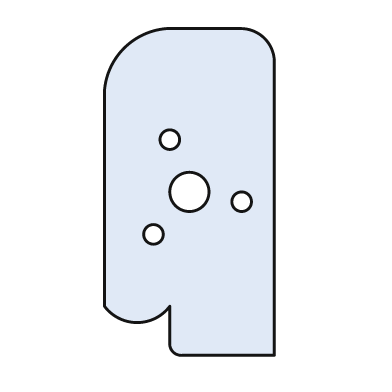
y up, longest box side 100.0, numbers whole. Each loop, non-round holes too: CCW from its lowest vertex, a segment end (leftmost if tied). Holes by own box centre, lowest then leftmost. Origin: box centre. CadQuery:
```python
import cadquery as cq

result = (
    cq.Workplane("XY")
    .moveTo(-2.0, -50.0)
    .lineTo(26.0, -50.0)
    .lineTo(26.0, 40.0)
    .threePointArc((23.0, 47.0), (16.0, 50.0))
    .lineTo(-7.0, 50.0)
    .threePointArc((-20.0, 44.0), (-26.0, 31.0))
    .lineTo(-26.0, -35.0)
    .threePointArc((-16.0, -40.0), (-6.0, -35.0))
    .lineTo(-6.0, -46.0)
    .threePointArc((-5.0, -49.0), (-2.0, -50.0))
    .close()
    .moveTo(-11.0, -13.0)
    .circle(3.0)
    .moveTo(16.0, -3.0)
    .circle(3.0)
    .moveTo(0.0, 0.0)
    .circle(6.0)
    .moveTo(-6.0, 16.0)
    .circle(3.0)
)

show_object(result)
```